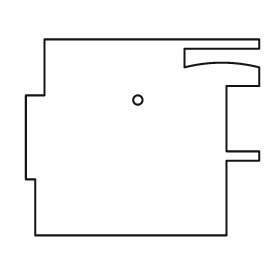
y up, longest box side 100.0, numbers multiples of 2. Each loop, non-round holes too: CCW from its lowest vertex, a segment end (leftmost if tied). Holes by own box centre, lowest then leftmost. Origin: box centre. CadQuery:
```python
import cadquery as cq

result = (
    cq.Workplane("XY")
    .moveTo(-46.0, -42.0)
    .lineTo(36.0, -42.0)
    .lineTo(36.0, -10.0)
    .lineTo(50.0, -10.0)
    .lineTo(50.0, -6.0)
    .lineTo(36.0, -6.0)
    .lineTo(36.0, 22.0)
    .lineTo(50.0, 22.0)
    .lineTo(50.0, 30.0)
    .threePointArc((34.0, 32.0), (18.0, 30.0))
    .lineTo(18.0, 38.0)
    .lineTo(50.0, 38.0)
    .lineTo(50.0, 42.0)
    .lineTo(-42.0, 42.0)
    .lineTo(-42.0, 18.0)
    .lineTo(-50.0, 18.0)
    .lineTo(-50.0, -18.0)
    .lineTo(-46.0, -18.0)
    .close()
    .moveTo(-2.0, 16.0)
    .circle(2.0)
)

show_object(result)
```